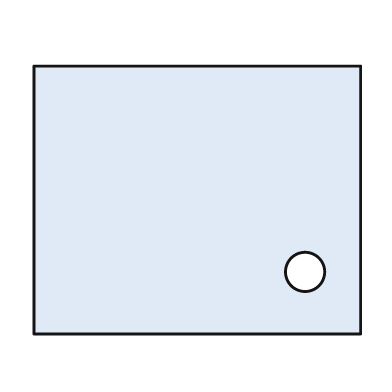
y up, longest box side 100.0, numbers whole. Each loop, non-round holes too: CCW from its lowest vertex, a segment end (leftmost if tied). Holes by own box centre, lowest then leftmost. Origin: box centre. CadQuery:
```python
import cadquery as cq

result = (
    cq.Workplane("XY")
    .moveTo(-50.0, -41.0)
    .lineTo(50.0, -41.0)
    .lineTo(50.0, 41.0)
    .lineTo(-50.0, 41.0)
    .close()
    .moveTo(33.0, -22.0)
    .circle(6.0)
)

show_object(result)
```